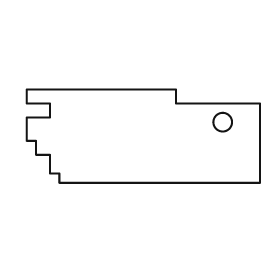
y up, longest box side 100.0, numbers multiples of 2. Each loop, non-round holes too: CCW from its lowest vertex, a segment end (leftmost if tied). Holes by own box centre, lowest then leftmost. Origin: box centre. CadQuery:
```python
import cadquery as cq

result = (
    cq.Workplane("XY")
    .moveTo(-36.0, -20.0)
    .lineTo(50.0, -20.0)
    .lineTo(50.0, 14.0)
    .lineTo(14.0, 14.0)
    .lineTo(14.0, 20.0)
    .lineTo(-50.0, 20.0)
    .lineTo(-50.0, 14.0)
    .lineTo(-40.0, 14.0)
    .lineTo(-40.0, 8.0)
    .lineTo(-50.0, 8.0)
    .lineTo(-50.0, -2.0)
    .lineTo(-46.0, -2.0)
    .lineTo(-46.0, -8.0)
    .lineTo(-40.0, -8.0)
    .lineTo(-40.0, -16.0)
    .lineTo(-36.0, -16.0)
    .close()
    .moveTo(34.0, 6.0)
    .circle(4.0)
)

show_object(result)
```